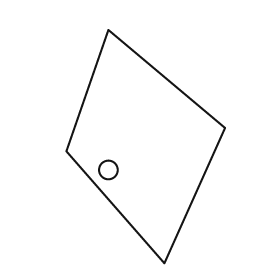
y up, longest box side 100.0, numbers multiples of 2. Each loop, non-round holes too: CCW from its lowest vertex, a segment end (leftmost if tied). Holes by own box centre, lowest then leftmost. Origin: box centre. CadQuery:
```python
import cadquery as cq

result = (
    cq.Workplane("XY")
    .moveTo(8.0, -50.0)
    .lineTo(34.0, 8.0)
    .lineTo(-16.0, 50.0)
    .lineTo(-34.0, -2.0)
    .close()
    .moveTo(-16.0, -10.0)
    .circle(4.0)
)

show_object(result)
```